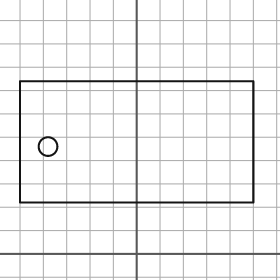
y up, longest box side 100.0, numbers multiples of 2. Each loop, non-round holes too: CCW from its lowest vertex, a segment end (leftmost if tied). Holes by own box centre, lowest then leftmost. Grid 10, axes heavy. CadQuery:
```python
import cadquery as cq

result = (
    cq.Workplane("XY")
    .moveTo(-50.0, 22.0)
    .lineTo(50.0, 22.0)
    .lineTo(50.0, 74.0)
    .lineTo(-50.0, 74.0)
    .close()
    .moveTo(-38.0, 46.0)
    .circle(4.0)
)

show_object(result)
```